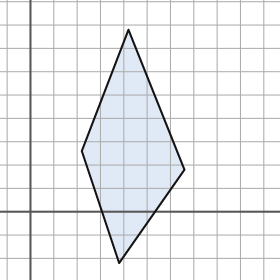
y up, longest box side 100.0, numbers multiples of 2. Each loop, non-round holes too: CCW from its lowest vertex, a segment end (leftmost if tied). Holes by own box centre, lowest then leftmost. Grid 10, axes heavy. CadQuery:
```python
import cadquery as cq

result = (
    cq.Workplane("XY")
    .moveTo(38.0, -22.0)
    .lineTo(66.0, 18.0)
    .lineTo(42.0, 78.0)
    .lineTo(22.0, 26.0)
    .close()
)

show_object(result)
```